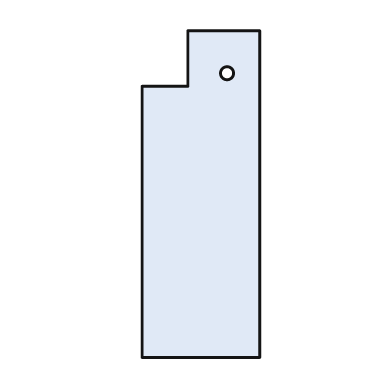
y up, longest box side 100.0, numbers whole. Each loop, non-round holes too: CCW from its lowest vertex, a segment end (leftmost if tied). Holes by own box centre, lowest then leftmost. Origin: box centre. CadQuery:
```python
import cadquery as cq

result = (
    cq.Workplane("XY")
    .moveTo(-18.0, -50.0)
    .lineTo(18.0, -50.0)
    .lineTo(18.0, 50.0)
    .lineTo(-4.0, 50.0)
    .lineTo(-4.0, 33.0)
    .lineTo(-18.0, 33.0)
    .close()
    .moveTo(8.0, 37.0)
    .circle(2.0)
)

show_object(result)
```